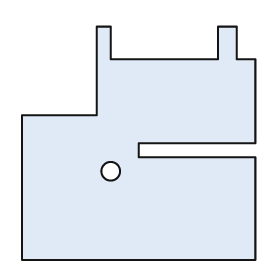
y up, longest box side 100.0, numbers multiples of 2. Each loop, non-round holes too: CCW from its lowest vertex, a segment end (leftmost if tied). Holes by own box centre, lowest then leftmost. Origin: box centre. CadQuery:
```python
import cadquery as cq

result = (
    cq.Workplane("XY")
    .moveTo(-50.0, -50.0)
    .lineTo(50.0, -50.0)
    .lineTo(50.0, -6.0)
    .lineTo(0.0, -6.0)
    .lineTo(0.0, 0.0)
    .lineTo(50.0, 0.0)
    .lineTo(50.0, 36.0)
    .lineTo(42.0, 36.0)
    .lineTo(42.0, 50.0)
    .lineTo(34.0, 50.0)
    .lineTo(34.0, 36.0)
    .lineTo(-12.0, 36.0)
    .lineTo(-12.0, 50.0)
    .lineTo(-18.0, 50.0)
    .lineTo(-18.0, 12.0)
    .lineTo(-50.0, 12.0)
    .close()
    .moveTo(-12.0, -12.0)
    .circle(4.0)
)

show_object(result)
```